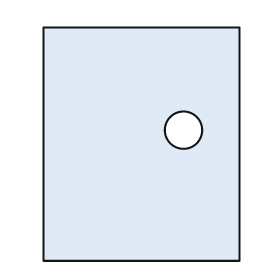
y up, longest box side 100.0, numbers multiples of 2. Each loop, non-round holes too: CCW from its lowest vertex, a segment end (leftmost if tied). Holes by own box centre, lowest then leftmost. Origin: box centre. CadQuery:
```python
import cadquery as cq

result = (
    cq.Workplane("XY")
    .moveTo(-42.0, -50.0)
    .lineTo(42.0, -50.0)
    .lineTo(42.0, 50.0)
    .lineTo(-42.0, 50.0)
    .close()
    .moveTo(18.0, 6.0)
    .circle(8.0)
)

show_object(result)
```